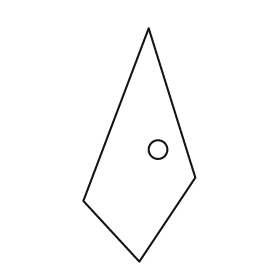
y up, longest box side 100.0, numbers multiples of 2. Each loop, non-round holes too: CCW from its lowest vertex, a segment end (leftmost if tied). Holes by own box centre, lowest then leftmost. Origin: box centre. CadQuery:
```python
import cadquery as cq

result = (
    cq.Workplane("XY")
    .moveTo(0.0, -50.0)
    .lineTo(24.0, -14.0)
    .lineTo(4.0, 50.0)
    .lineTo(-24.0, -24.0)
    .close()
    .moveTo(8.0, -2.0)
    .circle(4.0)
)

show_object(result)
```